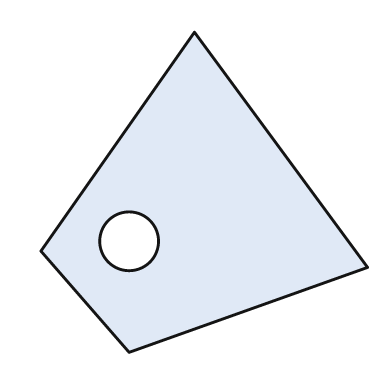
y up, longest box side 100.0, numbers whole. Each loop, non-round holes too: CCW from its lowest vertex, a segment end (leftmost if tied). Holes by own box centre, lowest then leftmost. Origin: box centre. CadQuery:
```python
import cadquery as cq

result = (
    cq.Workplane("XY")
    .moveTo(-23.0, -49.0)
    .lineTo(50.0, -23.0)
    .lineTo(-3.0, 49.0)
    .lineTo(-50.0, -18.0)
    .close()
    .moveTo(-23.0, -15.0)
    .circle(9.0)
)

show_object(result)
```